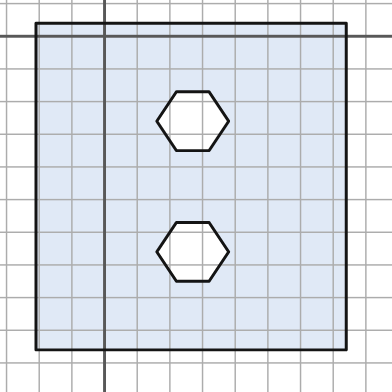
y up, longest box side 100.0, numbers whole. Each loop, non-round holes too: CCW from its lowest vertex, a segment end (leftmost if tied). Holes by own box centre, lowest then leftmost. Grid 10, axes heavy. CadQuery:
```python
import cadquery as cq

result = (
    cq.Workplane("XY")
    .moveTo(-21.0, -96.0)
    .lineTo(74.0, -96.0)
    .lineTo(74.0, 4.0)
    .lineTo(-21.0, 4.0)
    .close()
    .moveTo(22.0, -75.0)
    .lineTo(32.0, -75.0)
    .lineTo(38.0, -66.0)
    .lineTo(32.0, -57.0)
    .lineTo(22.0, -57.0)
    .lineTo(16.0, -66.0)
    .close()
    .moveTo(22.0, -35.0)
    .lineTo(32.0, -35.0)
    .lineTo(38.0, -26.0)
    .lineTo(32.0, -17.0)
    .lineTo(22.0, -17.0)
    .lineTo(16.0, -26.0)
    .close()
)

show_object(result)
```